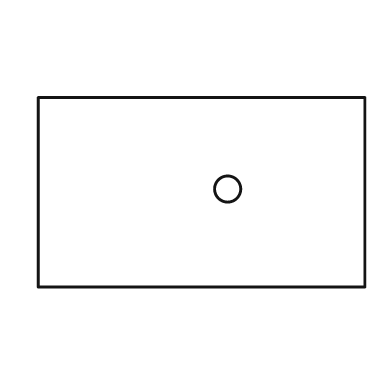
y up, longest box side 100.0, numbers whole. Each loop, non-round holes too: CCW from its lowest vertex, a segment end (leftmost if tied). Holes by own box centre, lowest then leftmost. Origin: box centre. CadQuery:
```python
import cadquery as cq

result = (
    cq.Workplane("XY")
    .moveTo(-50.0, -29.0)
    .lineTo(50.0, -29.0)
    .lineTo(50.0, 29.0)
    .lineTo(-50.0, 29.0)
    .close()
    .moveTo(8.0, 1.0)
    .circle(4.0)
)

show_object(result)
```